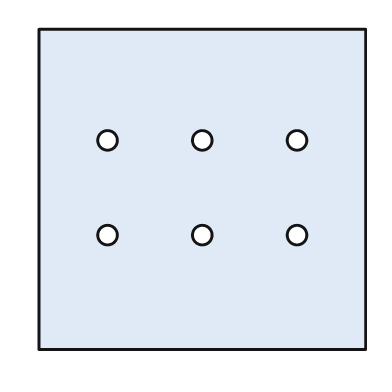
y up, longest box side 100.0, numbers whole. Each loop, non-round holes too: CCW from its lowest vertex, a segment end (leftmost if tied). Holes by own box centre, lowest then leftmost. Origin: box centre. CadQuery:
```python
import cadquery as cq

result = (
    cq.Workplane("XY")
    .moveTo(-50.0, -49.0)
    .lineTo(50.0, -49.0)
    .lineTo(50.0, 49.0)
    .lineTo(-50.0, 49.0)
    .close()
    .moveTo(-29.0, -14.0)
    .circle(3.0)
    .moveTo(0.0, -14.0)
    .circle(3.0)
    .moveTo(29.0, -14.0)
    .circle(3.0)
    .moveTo(-29.0, 15.0)
    .circle(3.0)
    .moveTo(0.0, 15.0)
    .circle(3.0)
    .moveTo(29.0, 15.0)
    .circle(3.0)
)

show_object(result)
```